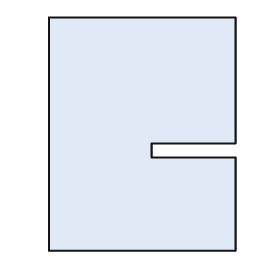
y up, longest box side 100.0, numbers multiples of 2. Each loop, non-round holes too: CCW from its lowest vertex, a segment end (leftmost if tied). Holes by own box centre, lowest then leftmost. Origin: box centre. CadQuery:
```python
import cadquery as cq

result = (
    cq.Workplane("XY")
    .moveTo(-40.0, -50.0)
    .lineTo(40.0, -50.0)
    .lineTo(40.0, -10.0)
    .lineTo(4.0, -10.0)
    .lineTo(4.0, -4.0)
    .lineTo(40.0, -4.0)
    .lineTo(40.0, 50.0)
    .lineTo(-40.0, 50.0)
    .close()
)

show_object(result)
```